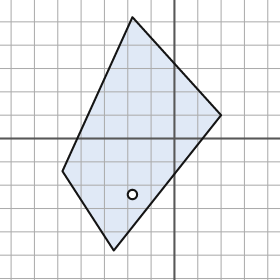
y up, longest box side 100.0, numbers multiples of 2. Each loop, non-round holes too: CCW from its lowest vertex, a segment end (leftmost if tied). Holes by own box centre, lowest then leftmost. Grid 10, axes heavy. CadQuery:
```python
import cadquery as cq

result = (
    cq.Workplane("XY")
    .moveTo(-26.0, -48.0)
    .lineTo(20.0, 10.0)
    .lineTo(-18.0, 52.0)
    .lineTo(-48.0, -14.0)
    .close()
    .moveTo(-18.0, -24.0)
    .circle(2.0)
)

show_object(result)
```